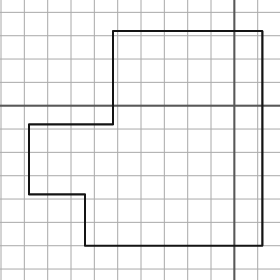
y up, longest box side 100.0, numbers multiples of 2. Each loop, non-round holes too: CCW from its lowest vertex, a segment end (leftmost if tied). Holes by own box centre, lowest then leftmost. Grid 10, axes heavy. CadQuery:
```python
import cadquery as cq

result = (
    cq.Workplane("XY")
    .moveTo(-64.0, -60.0)
    .lineTo(12.0, -60.0)
    .lineTo(12.0, 32.0)
    .lineTo(-52.0, 32.0)
    .lineTo(-52.0, -8.0)
    .lineTo(-88.0, -8.0)
    .lineTo(-88.0, -38.0)
    .lineTo(-64.0, -38.0)
    .close()
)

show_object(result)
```